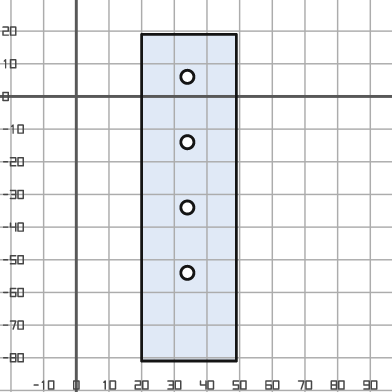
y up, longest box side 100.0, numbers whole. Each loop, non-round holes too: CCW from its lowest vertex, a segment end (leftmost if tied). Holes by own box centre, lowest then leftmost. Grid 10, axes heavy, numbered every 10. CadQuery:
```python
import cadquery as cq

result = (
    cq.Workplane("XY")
    .moveTo(20.0, -81.0)
    .lineTo(49.0, -81.0)
    .lineTo(49.0, 19.0)
    .lineTo(20.0, 19.0)
    .close()
    .moveTo(34.0, -54.0)
    .circle(2.0)
    .moveTo(34.0, -34.0)
    .circle(2.0)
    .moveTo(34.0, -14.0)
    .circle(2.0)
    .moveTo(34.0, 6.0)
    .circle(2.0)
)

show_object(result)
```